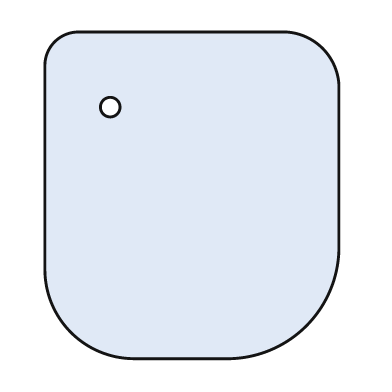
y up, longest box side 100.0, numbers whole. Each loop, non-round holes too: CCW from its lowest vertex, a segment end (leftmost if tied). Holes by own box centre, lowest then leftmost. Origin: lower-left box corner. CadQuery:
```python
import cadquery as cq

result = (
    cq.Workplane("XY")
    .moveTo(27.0, 0.0)
    .lineTo(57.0, 0.0)
    .threePointArc((80.0, 10.0), (90.0, 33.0))
    .lineTo(90.0, 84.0)
    .threePointArc((85.0, 95.0), (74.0, 100.0))
    .lineTo(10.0, 100.0)
    .threePointArc((3.0, 97.0), (0.0, 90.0))
    .lineTo(0.0, 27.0)
    .threePointArc((8.0, 8.0), (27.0, 0.0))
    .close()
    .moveTo(20.0, 77.0)
    .circle(3.0)
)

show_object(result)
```